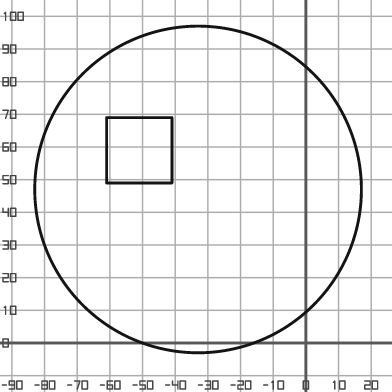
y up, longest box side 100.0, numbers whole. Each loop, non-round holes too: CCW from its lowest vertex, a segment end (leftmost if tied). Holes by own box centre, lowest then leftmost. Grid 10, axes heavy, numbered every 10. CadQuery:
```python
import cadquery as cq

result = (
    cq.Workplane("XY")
    .moveTo(-33.0, 47.0)
    .circle(50.0)
    .moveTo(-61.0, 49.0)
    .lineTo(-41.0, 49.0)
    .lineTo(-41.0, 69.0)
    .lineTo(-61.0, 69.0)
    .close()
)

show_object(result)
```